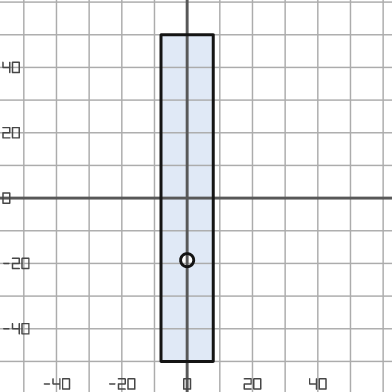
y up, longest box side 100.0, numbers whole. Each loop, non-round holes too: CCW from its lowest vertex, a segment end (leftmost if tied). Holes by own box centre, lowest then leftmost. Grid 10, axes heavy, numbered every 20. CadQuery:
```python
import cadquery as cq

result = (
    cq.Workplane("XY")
    .moveTo(-8.0, -50.0)
    .lineTo(8.0, -50.0)
    .lineTo(8.0, 50.0)
    .lineTo(-8.0, 50.0)
    .close()
    .moveTo(0.0, -19.0)
    .circle(2.0)
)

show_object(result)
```